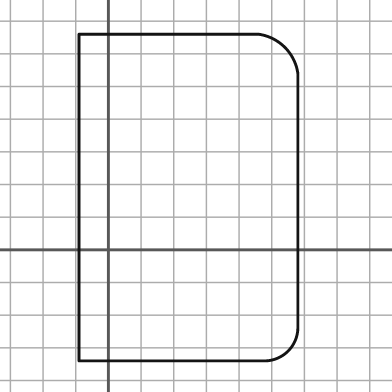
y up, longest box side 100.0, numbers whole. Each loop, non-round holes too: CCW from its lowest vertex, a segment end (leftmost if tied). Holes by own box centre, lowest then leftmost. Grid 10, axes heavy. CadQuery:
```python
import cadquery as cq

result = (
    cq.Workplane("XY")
    .moveTo(-9.0, -34.0)
    .lineTo(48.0, -34.0)
    .threePointArc((55.0, -31.0), (58.0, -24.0))
    .lineTo(58.0, 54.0)
    .threePointArc((54.0, 62.0), (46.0, 66.0))
    .lineTo(-9.0, 66.0)
    .close()
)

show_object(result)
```